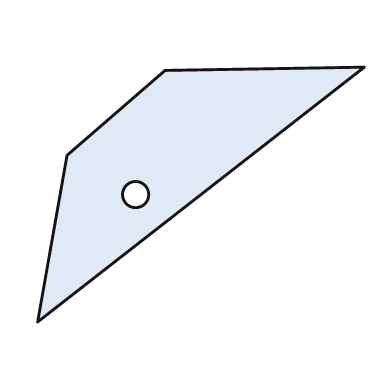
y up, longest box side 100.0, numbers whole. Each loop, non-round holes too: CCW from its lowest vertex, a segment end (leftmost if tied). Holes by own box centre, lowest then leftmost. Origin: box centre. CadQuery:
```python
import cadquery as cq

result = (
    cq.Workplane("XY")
    .moveTo(-50.0, -39.0)
    .lineTo(50.0, 39.0)
    .lineTo(-11.0, 38.0)
    .lineTo(-41.0, 12.0)
    .close()
    .moveTo(-20.0, 0.0)
    .circle(4.0)
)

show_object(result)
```